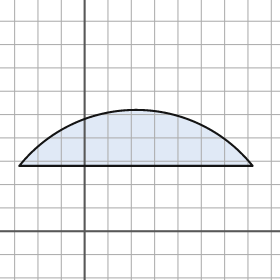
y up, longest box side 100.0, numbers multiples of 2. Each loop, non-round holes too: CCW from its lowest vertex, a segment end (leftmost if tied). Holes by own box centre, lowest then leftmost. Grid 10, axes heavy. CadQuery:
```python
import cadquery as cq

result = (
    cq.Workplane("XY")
    .moveTo(-28.0, 28.0)
    .lineTo(72.0, 28.0)
    .threePointArc((22.0, 52.0), (-28.0, 28.0))
    .close()
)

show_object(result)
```